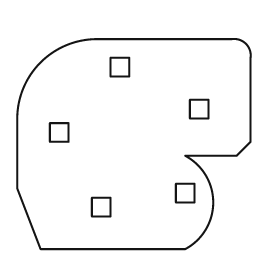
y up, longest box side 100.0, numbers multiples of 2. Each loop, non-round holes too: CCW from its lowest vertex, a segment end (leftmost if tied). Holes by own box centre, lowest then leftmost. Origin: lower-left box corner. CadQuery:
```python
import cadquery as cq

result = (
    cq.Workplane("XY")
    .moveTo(10.0, 0.0)
    .lineTo(72.0, 0.0)
    .threePointArc((84.0, 20.0), (72.0, 40.0))
    .lineTo(94.0, 40.0)
    .lineTo(100.0, 46.0)
    .lineTo(100.0, 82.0)
    .threePointArc((98.0, 88.0), (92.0, 90.0))
    .lineTo(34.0, 90.0)
    .threePointArc((10.0, 80.0), (0.0, 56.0))
    .lineTo(0.0, 26.0)
    .close()
    .moveTo(32.0, 14.0)
    .lineTo(40.0, 14.0)
    .lineTo(40.0, 22.0)
    .lineTo(32.0, 22.0)
    .close()
    .moveTo(68.0, 20.0)
    .lineTo(76.0, 20.0)
    .lineTo(76.0, 28.0)
    .lineTo(68.0, 28.0)
    .close()
    .moveTo(14.0, 46.0)
    .lineTo(22.0, 46.0)
    .lineTo(22.0, 54.0)
    .lineTo(14.0, 54.0)
    .close()
    .moveTo(74.0, 56.0)
    .lineTo(82.0, 56.0)
    .lineTo(82.0, 64.0)
    .lineTo(74.0, 64.0)
    .close()
    .moveTo(40.0, 74.0)
    .lineTo(48.0, 74.0)
    .lineTo(48.0, 82.0)
    .lineTo(40.0, 82.0)
    .close()
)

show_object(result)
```